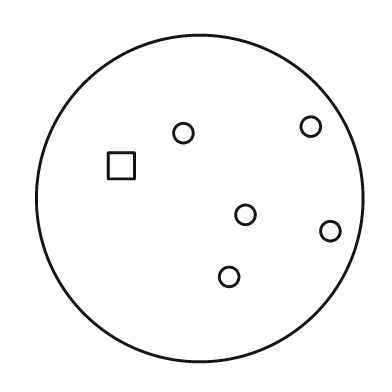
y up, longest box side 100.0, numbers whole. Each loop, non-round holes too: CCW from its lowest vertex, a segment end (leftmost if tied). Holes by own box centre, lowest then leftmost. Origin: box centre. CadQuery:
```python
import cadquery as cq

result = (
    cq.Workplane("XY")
    .moveTo(0.0, 0.0)
    .circle(50.0)
    .moveTo(9.0, -24.0)
    .circle(3.0)
    .moveTo(40.0, -10.0)
    .circle(3.0)
    .moveTo(14.0, -5.0)
    .circle(3.0)
    .moveTo(-28.0, 6.0)
    .lineTo(-20.0, 6.0)
    .lineTo(-20.0, 14.0)
    .lineTo(-28.0, 14.0)
    .close()
    .moveTo(-5.0, 20.0)
    .circle(3.0)
    .moveTo(34.0, 22.0)
    .circle(3.0)
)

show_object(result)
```